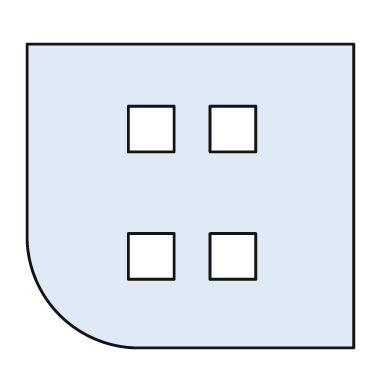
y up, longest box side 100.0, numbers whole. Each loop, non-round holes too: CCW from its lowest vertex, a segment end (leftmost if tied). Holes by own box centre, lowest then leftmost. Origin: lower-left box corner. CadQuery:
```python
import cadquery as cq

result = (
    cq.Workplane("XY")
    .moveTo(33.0, 0.0)
    .lineTo(100.0, 0.0)
    .lineTo(100.0, 93.0)
    .lineTo(0.0, 93.0)
    .lineTo(0.0, 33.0)
    .threePointArc((10.0, 10.0), (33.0, 0.0))
    .close()
    .moveTo(31.0, 21.0)
    .lineTo(45.0, 21.0)
    .lineTo(45.0, 35.0)
    .lineTo(31.0, 35.0)
    .close()
    .moveTo(56.0, 21.0)
    .lineTo(70.0, 21.0)
    .lineTo(70.0, 35.0)
    .lineTo(56.0, 35.0)
    .close()
    .moveTo(31.0, 60.0)
    .lineTo(45.0, 60.0)
    .lineTo(45.0, 74.0)
    .lineTo(31.0, 74.0)
    .close()
    .moveTo(56.0, 60.0)
    .lineTo(70.0, 60.0)
    .lineTo(70.0, 74.0)
    .lineTo(56.0, 74.0)
    .close()
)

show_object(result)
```